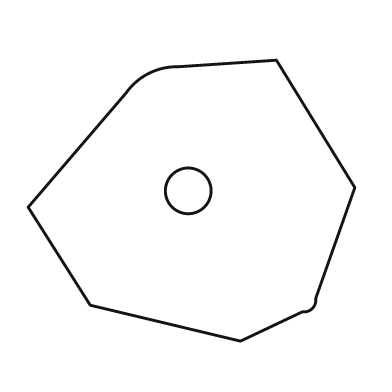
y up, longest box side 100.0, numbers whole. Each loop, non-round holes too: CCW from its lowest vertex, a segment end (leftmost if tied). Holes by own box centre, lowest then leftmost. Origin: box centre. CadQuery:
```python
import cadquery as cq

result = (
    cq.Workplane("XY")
    .moveTo(15.0, -43.0)
    .lineTo(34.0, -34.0)
    .threePointArc((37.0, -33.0), (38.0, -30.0))
    .lineTo(50.0, 4.0)
    .lineTo(26.0, 43.0)
    .lineTo(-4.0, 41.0)
    .threePointArc((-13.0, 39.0), (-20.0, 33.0))
    .lineTo(-50.0, -2.0)
    .lineTo(-31.0, -32.0)
    .close()
    .moveTo(-1.0, 3.0)
    .circle(7.0)
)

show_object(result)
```